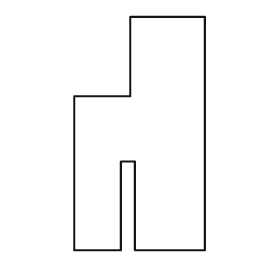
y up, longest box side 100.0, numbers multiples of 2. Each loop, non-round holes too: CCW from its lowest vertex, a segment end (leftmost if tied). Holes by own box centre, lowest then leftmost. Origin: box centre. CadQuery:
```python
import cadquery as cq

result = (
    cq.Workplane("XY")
    .moveTo(-28.0, -50.0)
    .lineTo(-8.0, -50.0)
    .lineTo(-8.0, -12.0)
    .lineTo(-2.0, -12.0)
    .lineTo(-2.0, -50.0)
    .lineTo(28.0, -50.0)
    .lineTo(28.0, 50.0)
    .lineTo(-4.0, 50.0)
    .lineTo(-4.0, 16.0)
    .lineTo(-28.0, 16.0)
    .close()
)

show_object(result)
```